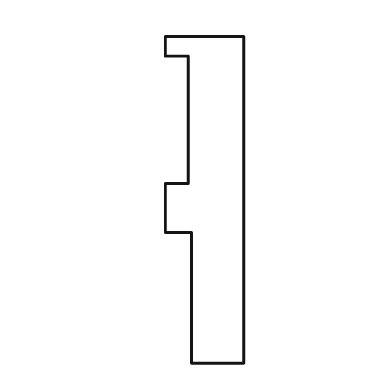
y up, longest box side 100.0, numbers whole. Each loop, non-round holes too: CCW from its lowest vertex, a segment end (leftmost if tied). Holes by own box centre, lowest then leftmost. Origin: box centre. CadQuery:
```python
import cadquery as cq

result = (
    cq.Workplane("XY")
    .moveTo(-4.0, -50.0)
    .lineTo(12.0, -50.0)
    .lineTo(12.0, 50.0)
    .lineTo(-12.0, 50.0)
    .lineTo(-12.0, 44.0)
    .lineTo(-5.0, 44.0)
    .lineTo(-5.0, 5.0)
    .lineTo(-12.0, 5.0)
    .lineTo(-12.0, -10.0)
    .lineTo(-4.0, -10.0)
    .close()
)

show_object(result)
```